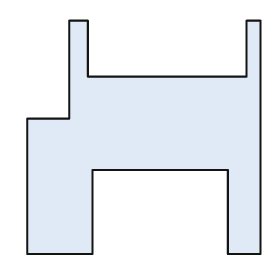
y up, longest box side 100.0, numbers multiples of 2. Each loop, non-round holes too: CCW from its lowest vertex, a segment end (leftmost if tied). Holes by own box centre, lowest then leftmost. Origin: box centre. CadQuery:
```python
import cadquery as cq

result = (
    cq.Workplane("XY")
    .moveTo(-50.0, -50.0)
    .lineTo(-22.0, -50.0)
    .lineTo(-22.0, -14.0)
    .lineTo(36.0, -14.0)
    .lineTo(36.0, -50.0)
    .lineTo(50.0, -50.0)
    .lineTo(50.0, 50.0)
    .lineTo(44.0, 50.0)
    .lineTo(44.0, 26.0)
    .lineTo(-24.0, 26.0)
    .lineTo(-24.0, 50.0)
    .lineTo(-32.0, 50.0)
    .lineTo(-32.0, 8.0)
    .lineTo(-50.0, 8.0)
    .close()
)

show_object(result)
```